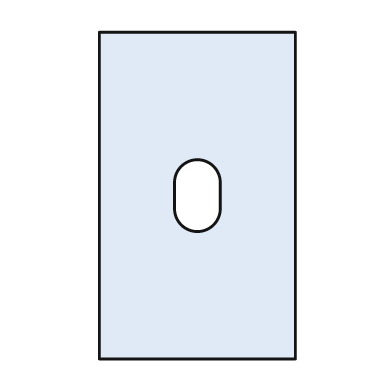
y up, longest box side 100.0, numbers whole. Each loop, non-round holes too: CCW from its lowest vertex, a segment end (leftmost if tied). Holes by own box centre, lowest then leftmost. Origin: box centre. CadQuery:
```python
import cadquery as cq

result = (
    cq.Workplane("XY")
    .moveTo(-30.0, -50.0)
    .lineTo(30.0, -50.0)
    .lineTo(30.0, 50.0)
    .lineTo(-30.0, 50.0)
    .close()
    .moveTo(-7.0, -4.0)
    .threePointArc((0.0, -11.0), (7.0, -4.0))
    .lineTo(7.0, 4.0)
    .threePointArc((0.0, 11.0), (-7.0, 4.0))
    .close()
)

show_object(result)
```